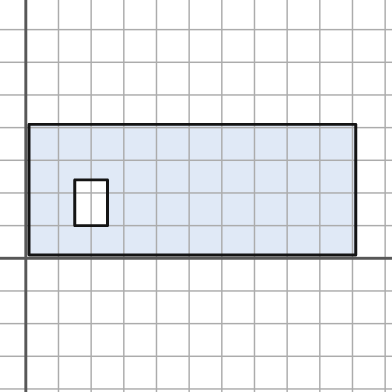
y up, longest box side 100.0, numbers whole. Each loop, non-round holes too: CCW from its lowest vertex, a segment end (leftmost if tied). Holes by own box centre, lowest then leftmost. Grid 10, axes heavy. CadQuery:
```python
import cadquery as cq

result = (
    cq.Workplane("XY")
    .moveTo(1.0, 1.0)
    .lineTo(101.0, 1.0)
    .lineTo(101.0, 41.0)
    .lineTo(1.0, 41.0)
    .close()
    .moveTo(15.0, 10.0)
    .lineTo(25.0, 10.0)
    .lineTo(25.0, 24.0)
    .lineTo(15.0, 24.0)
    .close()
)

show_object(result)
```